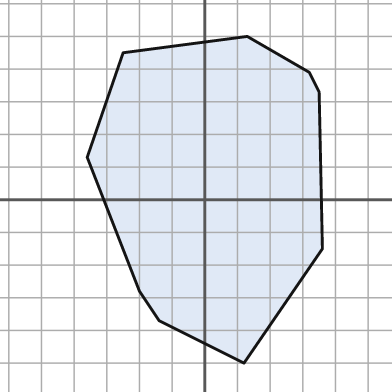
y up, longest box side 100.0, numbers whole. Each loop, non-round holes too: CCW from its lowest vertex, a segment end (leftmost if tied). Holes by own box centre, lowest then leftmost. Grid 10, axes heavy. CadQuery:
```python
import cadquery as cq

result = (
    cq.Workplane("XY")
    .moveTo(12.0, -50.0)
    .lineTo(36.0, -15.0)
    .lineTo(35.0, 33.0)
    .lineTo(32.0, 39.0)
    .lineTo(13.0, 50.0)
    .lineTo(-25.0, 45.0)
    .lineTo(-36.0, 13.0)
    .lineTo(-20.0, -28.0)
    .lineTo(-14.0, -37.0)
    .close()
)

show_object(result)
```